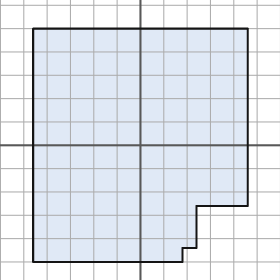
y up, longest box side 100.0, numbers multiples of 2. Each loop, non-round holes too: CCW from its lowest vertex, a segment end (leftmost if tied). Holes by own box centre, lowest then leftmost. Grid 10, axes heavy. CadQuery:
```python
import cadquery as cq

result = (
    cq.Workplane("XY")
    .moveTo(-46.0, -50.0)
    .lineTo(18.0, -50.0)
    .lineTo(18.0, -44.0)
    .lineTo(24.0, -44.0)
    .lineTo(24.0, -26.0)
    .lineTo(46.0, -26.0)
    .lineTo(46.0, 50.0)
    .lineTo(-46.0, 50.0)
    .close()
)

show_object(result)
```